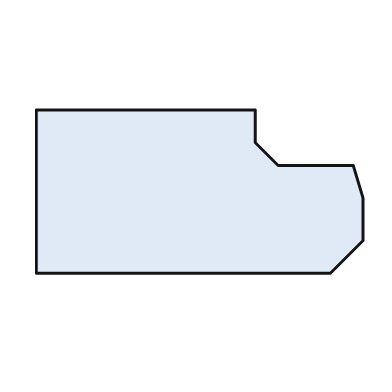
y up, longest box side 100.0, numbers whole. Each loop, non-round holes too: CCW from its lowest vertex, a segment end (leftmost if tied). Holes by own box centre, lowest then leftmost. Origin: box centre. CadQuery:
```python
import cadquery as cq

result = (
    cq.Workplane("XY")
    .moveTo(-50.0, -25.0)
    .lineTo(40.0, -25.0)
    .lineTo(50.0, -15.0)
    .lineTo(50.0, -2.0)
    .lineTo(47.0, 8.0)
    .lineTo(24.0, 8.0)
    .lineTo(17.0, 15.0)
    .lineTo(17.0, 25.0)
    .lineTo(-50.0, 25.0)
    .close()
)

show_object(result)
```